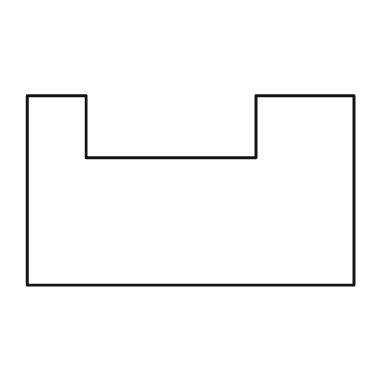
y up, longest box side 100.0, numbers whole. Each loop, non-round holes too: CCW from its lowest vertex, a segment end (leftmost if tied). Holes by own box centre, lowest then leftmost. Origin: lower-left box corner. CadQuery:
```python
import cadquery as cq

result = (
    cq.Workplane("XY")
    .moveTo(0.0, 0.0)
    .lineTo(100.0, 0.0)
    .lineTo(100.0, 58.0)
    .lineTo(70.0, 58.0)
    .lineTo(70.0, 39.0)
    .lineTo(18.0, 39.0)
    .lineTo(18.0, 58.0)
    .lineTo(0.0, 58.0)
    .close()
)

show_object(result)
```